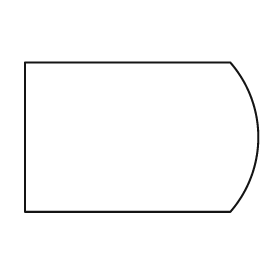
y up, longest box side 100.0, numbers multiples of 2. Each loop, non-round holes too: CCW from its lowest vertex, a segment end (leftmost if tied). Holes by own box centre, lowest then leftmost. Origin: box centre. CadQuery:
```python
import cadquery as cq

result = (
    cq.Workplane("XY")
    .moveTo(-50.0, -32.0)
    .lineTo(38.0, -32.0)
    .threePointArc((50.0, 0.0), (38.0, 32.0))
    .lineTo(-50.0, 32.0)
    .close()
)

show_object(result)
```